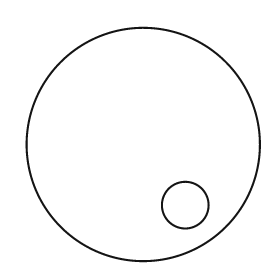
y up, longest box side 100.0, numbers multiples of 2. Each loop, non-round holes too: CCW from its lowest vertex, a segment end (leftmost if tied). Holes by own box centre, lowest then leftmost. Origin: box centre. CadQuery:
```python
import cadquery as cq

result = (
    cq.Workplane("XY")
    .moveTo(0.0, 0.0)
    .circle(50.0)
    .moveTo(18.0, -26.0)
    .circle(10.0)
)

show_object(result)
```